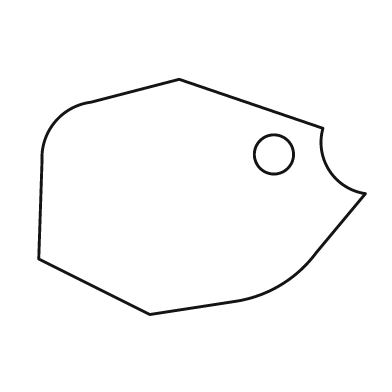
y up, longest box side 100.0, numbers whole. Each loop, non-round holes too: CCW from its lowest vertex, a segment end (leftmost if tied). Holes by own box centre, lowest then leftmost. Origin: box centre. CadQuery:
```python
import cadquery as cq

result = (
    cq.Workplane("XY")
    .moveTo(-16.0, -36.0)
    .lineTo(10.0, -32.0)
    .threePointArc((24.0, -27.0), (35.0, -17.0))
    .lineTo(50.0, 1.0)
    .threePointArc((39.0, 8.0), (37.0, 21.0))
    .lineTo(-7.0, 36.0)
    .lineTo(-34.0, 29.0)
    .threePointArc((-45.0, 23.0), (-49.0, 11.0))
    .lineTo(-50.0, -19.0)
    .close()
    .moveTo(22.0, 13.0)
    .circle(6.0)
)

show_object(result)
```